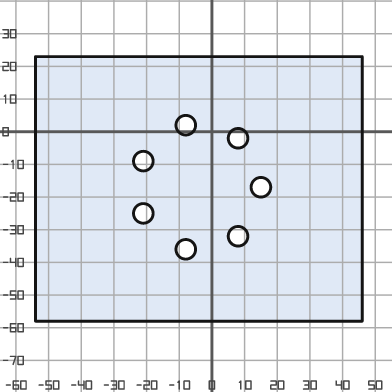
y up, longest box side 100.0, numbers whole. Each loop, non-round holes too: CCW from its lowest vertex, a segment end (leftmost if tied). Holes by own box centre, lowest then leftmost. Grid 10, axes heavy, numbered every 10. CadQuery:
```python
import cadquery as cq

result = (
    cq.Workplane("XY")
    .moveTo(-54.0, -58.0)
    .lineTo(46.0, -58.0)
    .lineTo(46.0, 23.0)
    .lineTo(-54.0, 23.0)
    .close()
    .moveTo(-8.0, -36.0)
    .circle(3.0)
    .moveTo(8.0, -32.0)
    .circle(3.0)
    .moveTo(-21.0, -25.0)
    .circle(3.0)
    .moveTo(15.0, -17.0)
    .circle(3.0)
    .moveTo(-21.0, -9.0)
    .circle(3.0)
    .moveTo(8.0, -2.0)
    .circle(3.0)
    .moveTo(-8.0, 2.0)
    .circle(3.0)
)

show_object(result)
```